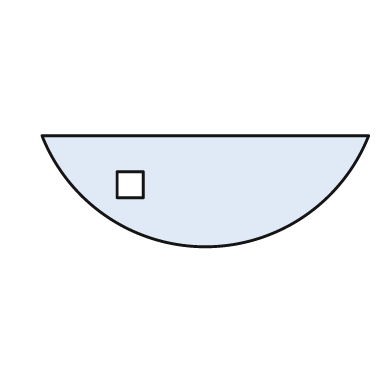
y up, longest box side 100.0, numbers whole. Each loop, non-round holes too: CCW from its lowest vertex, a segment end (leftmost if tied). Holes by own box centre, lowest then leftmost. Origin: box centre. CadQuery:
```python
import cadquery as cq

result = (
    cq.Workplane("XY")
    .moveTo(-50.0, 17.0)
    .threePointArc((0.0, -17.0), (50.0, 17.0))
    .close()
    .moveTo(-27.0, -2.0)
    .lineTo(-19.0, -2.0)
    .lineTo(-19.0, 6.0)
    .lineTo(-27.0, 6.0)
    .close()
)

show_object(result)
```